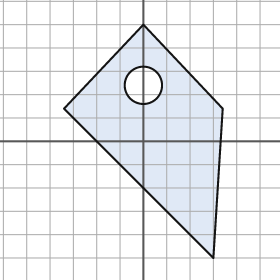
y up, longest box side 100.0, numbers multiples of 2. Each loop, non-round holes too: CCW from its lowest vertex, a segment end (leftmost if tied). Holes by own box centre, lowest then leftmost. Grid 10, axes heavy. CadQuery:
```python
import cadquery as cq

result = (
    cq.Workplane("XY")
    .moveTo(30.0, -50.0)
    .lineTo(34.0, 14.0)
    .lineTo(0.0, 50.0)
    .lineTo(-34.0, 14.0)
    .close()
    .moveTo(0.0, 24.0)
    .circle(8.0)
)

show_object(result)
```